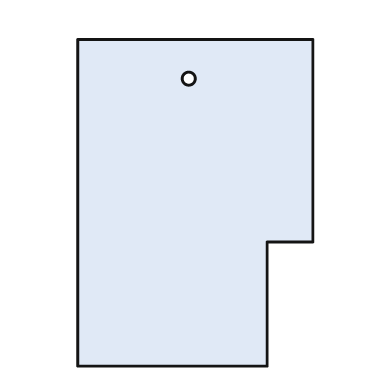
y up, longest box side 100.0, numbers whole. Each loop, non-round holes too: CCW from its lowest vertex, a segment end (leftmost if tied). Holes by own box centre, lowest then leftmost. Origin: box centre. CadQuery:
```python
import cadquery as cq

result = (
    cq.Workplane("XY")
    .moveTo(-36.0, -50.0)
    .lineTo(22.0, -50.0)
    .lineTo(22.0, -12.0)
    .lineTo(36.0, -12.0)
    .lineTo(36.0, 50.0)
    .lineTo(-36.0, 50.0)
    .close()
    .moveTo(-2.0, 38.0)
    .circle(2.0)
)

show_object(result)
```